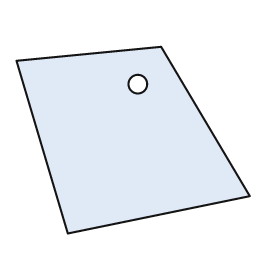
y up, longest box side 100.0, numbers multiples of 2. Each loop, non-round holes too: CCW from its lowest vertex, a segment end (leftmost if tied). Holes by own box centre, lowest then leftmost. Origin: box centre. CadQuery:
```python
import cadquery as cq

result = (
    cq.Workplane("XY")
    .moveTo(-28.0, -40.0)
    .lineTo(50.0, -24.0)
    .lineTo(12.0, 40.0)
    .lineTo(-50.0, 34.0)
    .close()
    .moveTo(2.0, 24.0)
    .circle(4.0)
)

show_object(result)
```